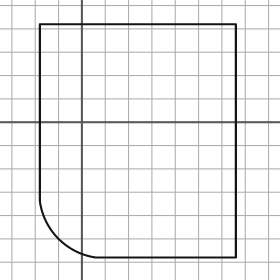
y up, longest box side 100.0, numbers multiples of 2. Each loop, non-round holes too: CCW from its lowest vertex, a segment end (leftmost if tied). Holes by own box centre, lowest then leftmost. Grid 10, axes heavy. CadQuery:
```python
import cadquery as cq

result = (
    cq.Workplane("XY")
    .moveTo(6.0, -58.0)
    .lineTo(66.0, -58.0)
    .lineTo(66.0, 42.0)
    .lineTo(-18.0, 42.0)
    .lineTo(-18.0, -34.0)
    .threePointArc((-10.0, -50.0), (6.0, -58.0))
    .close()
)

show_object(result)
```